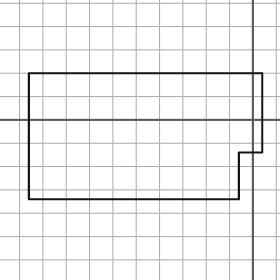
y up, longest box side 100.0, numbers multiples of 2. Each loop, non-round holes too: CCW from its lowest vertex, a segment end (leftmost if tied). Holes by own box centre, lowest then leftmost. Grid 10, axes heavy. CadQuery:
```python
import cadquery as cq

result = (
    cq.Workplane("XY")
    .moveTo(-96.0, -34.0)
    .lineTo(-6.0, -34.0)
    .lineTo(-6.0, -14.0)
    .lineTo(4.0, -14.0)
    .lineTo(4.0, 20.0)
    .lineTo(-96.0, 20.0)
    .close()
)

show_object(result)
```